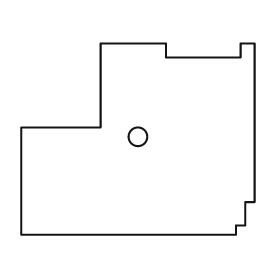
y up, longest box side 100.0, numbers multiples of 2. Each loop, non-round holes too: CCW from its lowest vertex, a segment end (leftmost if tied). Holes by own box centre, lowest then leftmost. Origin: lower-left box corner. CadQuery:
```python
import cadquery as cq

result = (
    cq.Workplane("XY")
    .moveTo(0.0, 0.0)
    .lineTo(92.0, 0.0)
    .lineTo(92.0, 4.0)
    .lineTo(96.0, 4.0)
    .lineTo(96.0, 14.0)
    .lineTo(100.0, 14.0)
    .lineTo(100.0, 82.0)
    .lineTo(94.0, 82.0)
    .lineTo(94.0, 76.0)
    .lineTo(62.0, 76.0)
    .lineTo(62.0, 82.0)
    .lineTo(34.0, 82.0)
    .lineTo(34.0, 46.0)
    .lineTo(0.0, 46.0)
    .close()
    .moveTo(50.0, 42.0)
    .circle(4.0)
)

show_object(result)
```